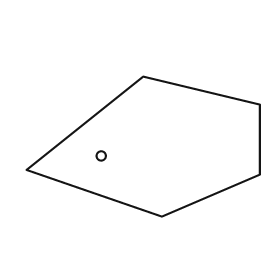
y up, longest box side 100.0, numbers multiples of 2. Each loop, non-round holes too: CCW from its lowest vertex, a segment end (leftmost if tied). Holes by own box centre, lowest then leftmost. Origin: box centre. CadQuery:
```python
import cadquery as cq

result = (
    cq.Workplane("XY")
    .moveTo(8.0, -30.0)
    .lineTo(50.0, -12.0)
    .lineTo(50.0, 18.0)
    .lineTo(0.0, 30.0)
    .lineTo(-50.0, -10.0)
    .close()
    .moveTo(-18.0, -4.0)
    .circle(2.0)
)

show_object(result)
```